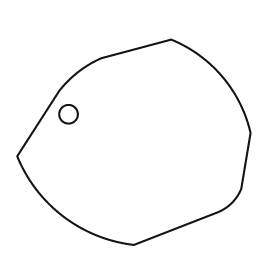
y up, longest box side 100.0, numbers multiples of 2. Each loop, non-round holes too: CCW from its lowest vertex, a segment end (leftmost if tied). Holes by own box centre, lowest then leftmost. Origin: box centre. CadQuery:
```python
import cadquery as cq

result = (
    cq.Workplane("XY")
    .moveTo(0.0, -44.0)
    .lineTo(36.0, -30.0)
    .threePointArc((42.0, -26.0), (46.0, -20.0))
    .lineTo(50.0, 4.0)
    .threePointArc((38.0, 28.0), (16.0, 44.0))
    .lineTo(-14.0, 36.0)
    .threePointArc((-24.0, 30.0), (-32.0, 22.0))
    .lineTo(-50.0, -6.0)
    .threePointArc((-30.0, -32.0), (0.0, -44.0))
    .close()
    .moveTo(-28.0, 12.0)
    .circle(4.0)
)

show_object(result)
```